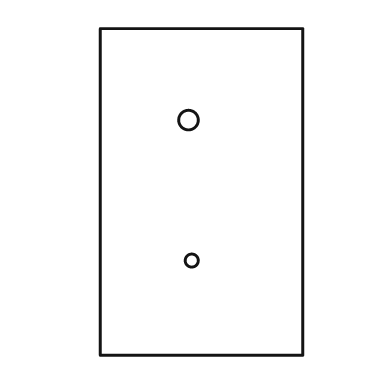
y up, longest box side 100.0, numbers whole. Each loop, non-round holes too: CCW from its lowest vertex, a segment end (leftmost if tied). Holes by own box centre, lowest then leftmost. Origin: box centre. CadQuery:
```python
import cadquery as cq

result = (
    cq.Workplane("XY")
    .moveTo(-31.0, -50.0)
    .lineTo(31.0, -50.0)
    .lineTo(31.0, 50.0)
    .lineTo(-31.0, 50.0)
    .close()
    .moveTo(-3.0, -21.0)
    .circle(2.0)
    .moveTo(-4.0, 22.0)
    .circle(3.0)
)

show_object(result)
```